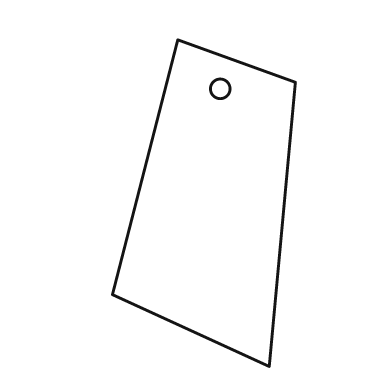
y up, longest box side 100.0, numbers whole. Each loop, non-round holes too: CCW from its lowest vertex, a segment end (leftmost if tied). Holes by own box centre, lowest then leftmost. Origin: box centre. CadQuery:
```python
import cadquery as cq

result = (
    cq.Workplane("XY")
    .moveTo(20.0, -50.0)
    .lineTo(28.0, 37.0)
    .lineTo(-8.0, 50.0)
    .lineTo(-28.0, -28.0)
    .close()
    .moveTo(5.0, 35.0)
    .circle(3.0)
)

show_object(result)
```